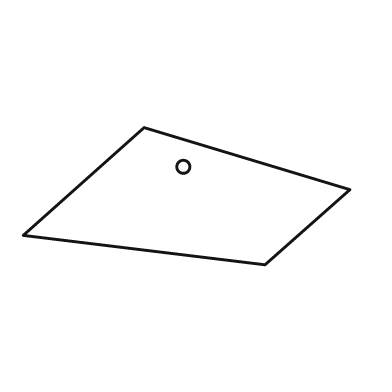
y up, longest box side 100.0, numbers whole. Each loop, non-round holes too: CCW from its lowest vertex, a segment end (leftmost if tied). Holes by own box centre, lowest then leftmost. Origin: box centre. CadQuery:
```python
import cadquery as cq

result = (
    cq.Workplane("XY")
    .moveTo(24.0, -21.0)
    .lineTo(50.0, 2.0)
    .lineTo(-13.0, 21.0)
    .lineTo(-50.0, -12.0)
    .close()
    .moveTo(-1.0, 9.0)
    .circle(2.0)
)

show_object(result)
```